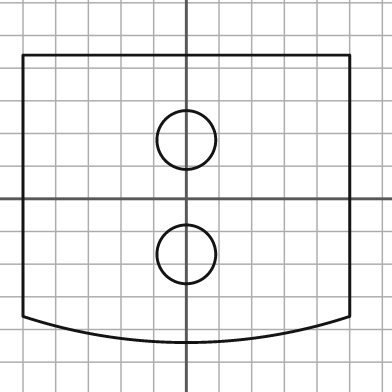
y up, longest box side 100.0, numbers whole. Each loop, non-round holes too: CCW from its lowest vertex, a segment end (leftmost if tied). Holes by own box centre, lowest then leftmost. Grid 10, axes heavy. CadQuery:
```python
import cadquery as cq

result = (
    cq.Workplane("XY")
    .moveTo(-50.0, -36.0)
    .threePointArc((0.0, -44.0), (50.0, -36.0))
    .lineTo(50.0, 44.0)
    .lineTo(-50.0, 44.0)
    .close()
    .moveTo(0.0, -17.0)
    .circle(9.0)
    .moveTo(0.0, 18.0)
    .circle(9.0)
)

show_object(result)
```